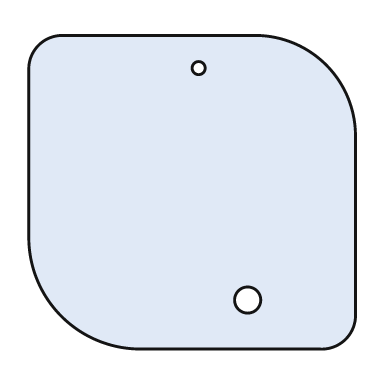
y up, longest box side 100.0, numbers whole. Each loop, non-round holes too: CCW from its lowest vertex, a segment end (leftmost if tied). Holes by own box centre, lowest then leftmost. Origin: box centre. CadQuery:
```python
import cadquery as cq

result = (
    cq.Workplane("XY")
    .moveTo(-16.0, -48.0)
    .lineTo(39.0, -48.0)
    .threePointArc((47.0, -45.0), (50.0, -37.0))
    .lineTo(50.0, 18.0)
    .threePointArc((41.0, 39.0), (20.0, 48.0))
    .lineTo(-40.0, 48.0)
    .threePointArc((-47.0, 45.0), (-50.0, 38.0))
    .lineTo(-50.0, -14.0)
    .threePointArc((-40.0, -38.0), (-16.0, -48.0))
    .close()
    .moveTo(17.0, -33.0)
    .circle(4.0)
    .moveTo(2.0, 38.0)
    .circle(2.0)
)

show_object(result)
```